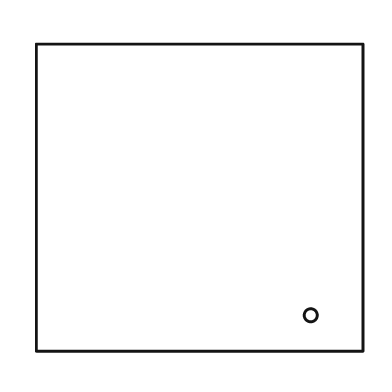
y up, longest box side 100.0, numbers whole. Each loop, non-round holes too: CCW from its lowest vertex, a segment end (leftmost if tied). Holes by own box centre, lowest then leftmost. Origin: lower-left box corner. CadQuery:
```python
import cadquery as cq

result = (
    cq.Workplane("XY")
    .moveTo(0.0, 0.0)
    .lineTo(100.0, 0.0)
    .lineTo(100.0, 94.0)
    .lineTo(0.0, 94.0)
    .close()
    .moveTo(84.0, 11.0)
    .circle(2.0)
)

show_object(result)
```